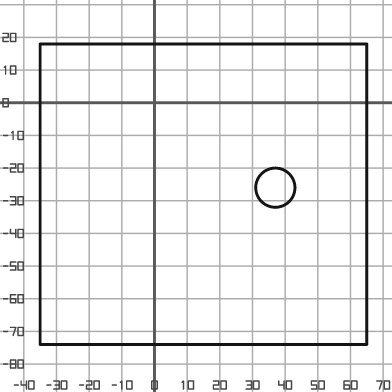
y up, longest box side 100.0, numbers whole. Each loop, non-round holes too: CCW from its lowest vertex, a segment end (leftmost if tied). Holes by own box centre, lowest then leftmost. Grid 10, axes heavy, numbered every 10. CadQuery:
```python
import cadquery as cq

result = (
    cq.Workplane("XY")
    .moveTo(-35.0, -74.0)
    .lineTo(65.0, -74.0)
    .lineTo(65.0, 18.0)
    .lineTo(-35.0, 18.0)
    .close()
    .moveTo(37.0, -26.0)
    .circle(6.0)
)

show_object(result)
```